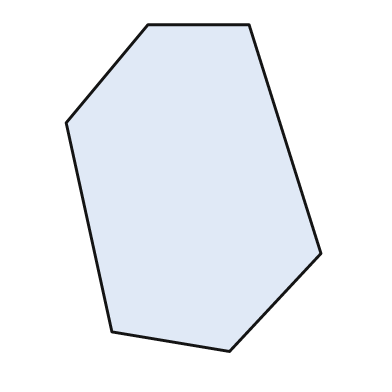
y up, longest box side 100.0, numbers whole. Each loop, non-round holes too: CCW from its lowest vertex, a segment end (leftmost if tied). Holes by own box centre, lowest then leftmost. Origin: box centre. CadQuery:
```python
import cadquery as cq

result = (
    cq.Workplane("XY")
    .moveTo(11.0, -50.0)
    .lineTo(39.0, -20.0)
    .lineTo(17.0, 50.0)
    .lineTo(-14.0, 50.0)
    .lineTo(-39.0, 20.0)
    .lineTo(-25.0, -44.0)
    .close()
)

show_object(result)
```